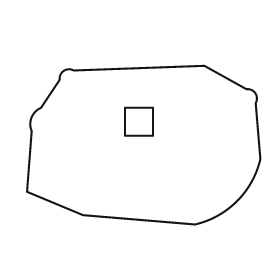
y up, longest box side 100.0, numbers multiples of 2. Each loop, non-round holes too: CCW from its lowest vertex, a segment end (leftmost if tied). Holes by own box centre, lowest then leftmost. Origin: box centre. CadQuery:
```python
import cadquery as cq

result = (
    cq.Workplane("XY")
    .moveTo(22.0, -34.0)
    .threePointArc((40.0, -24.0), (50.0, -6.0))
    .lineTo(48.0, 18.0)
    .threePointArc((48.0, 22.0), (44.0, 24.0))
    .lineTo(26.0, 34.0)
    .lineTo(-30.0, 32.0)
    .threePointArc((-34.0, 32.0), (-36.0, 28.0))
    .lineTo(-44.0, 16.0)
    .threePointArc((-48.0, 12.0), (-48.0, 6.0))
    .lineTo(-50.0, -20.0)
    .lineTo(-26.0, -30.0)
    .close()
    .moveTo(-8.0, 4.0)
    .lineTo(4.0, 4.0)
    .lineTo(4.0, 16.0)
    .lineTo(-8.0, 16.0)
    .close()
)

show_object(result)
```